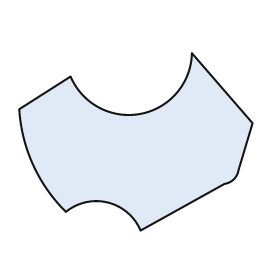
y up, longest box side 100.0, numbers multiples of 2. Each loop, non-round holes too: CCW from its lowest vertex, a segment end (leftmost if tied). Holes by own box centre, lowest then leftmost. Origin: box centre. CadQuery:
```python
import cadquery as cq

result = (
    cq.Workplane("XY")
    .moveTo(2.0, -38.0)
    .lineTo(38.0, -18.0)
    .threePointArc((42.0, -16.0), (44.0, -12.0))
    .lineTo(50.0, 8.0)
    .lineTo(24.0, 38.0)
    .threePointArc((2.0, 12.0), (-28.0, 28.0))
    .lineTo(-50.0, 14.0)
    .threePointArc((-44.0, -10.0), (-30.0, -30.0))
    .threePointArc((-12.0, -26.0), (2.0, -38.0))
    .close()
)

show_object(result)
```